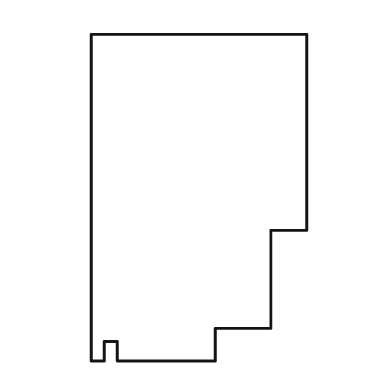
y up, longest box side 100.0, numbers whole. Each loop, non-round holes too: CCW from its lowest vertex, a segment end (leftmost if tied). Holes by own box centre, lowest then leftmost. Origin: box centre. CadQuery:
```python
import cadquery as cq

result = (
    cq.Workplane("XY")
    .moveTo(-33.0, -50.0)
    .lineTo(-29.0, -50.0)
    .lineTo(-29.0, -44.0)
    .lineTo(-25.0, -44.0)
    .lineTo(-25.0, -50.0)
    .lineTo(5.0, -50.0)
    .lineTo(5.0, -40.0)
    .lineTo(22.0, -40.0)
    .lineTo(22.0, -10.0)
    .lineTo(33.0, -10.0)
    .lineTo(33.0, 50.0)
    .lineTo(-33.0, 50.0)
    .close()
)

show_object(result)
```